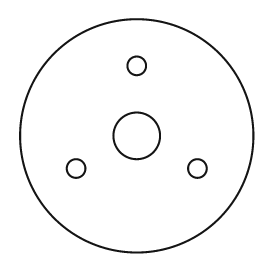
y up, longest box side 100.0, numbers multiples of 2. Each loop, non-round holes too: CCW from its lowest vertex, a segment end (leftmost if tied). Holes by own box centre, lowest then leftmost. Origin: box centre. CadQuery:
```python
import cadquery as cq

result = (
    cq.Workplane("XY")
    .moveTo(0.0, 0.0)
    .circle(50.0)
    .moveTo(-26.0, -14.0)
    .circle(4.0)
    .moveTo(26.0, -14.0)
    .circle(4.0)
    .moveTo(0.0, 0.0)
    .circle(10.0)
    .moveTo(0.0, 30.0)
    .circle(4.0)
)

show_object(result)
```